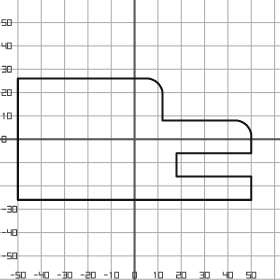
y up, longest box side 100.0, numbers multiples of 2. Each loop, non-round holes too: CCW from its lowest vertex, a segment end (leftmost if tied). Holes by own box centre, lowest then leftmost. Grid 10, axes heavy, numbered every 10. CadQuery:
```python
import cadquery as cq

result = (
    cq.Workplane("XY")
    .moveTo(-50.0, -26.0)
    .lineTo(50.0, -26.0)
    .lineTo(50.0, -16.0)
    .lineTo(18.0, -16.0)
    .lineTo(18.0, -6.0)
    .lineTo(50.0, -6.0)
    .lineTo(50.0, 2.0)
    .threePointArc((48.0, 6.0), (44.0, 8.0))
    .lineTo(12.0, 8.0)
    .lineTo(12.0, 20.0)
    .threePointArc((10.0, 24.0), (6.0, 26.0))
    .lineTo(-50.0, 26.0)
    .close()
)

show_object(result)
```